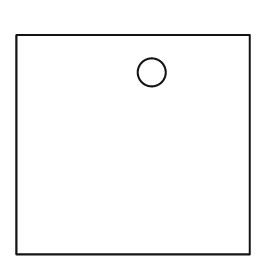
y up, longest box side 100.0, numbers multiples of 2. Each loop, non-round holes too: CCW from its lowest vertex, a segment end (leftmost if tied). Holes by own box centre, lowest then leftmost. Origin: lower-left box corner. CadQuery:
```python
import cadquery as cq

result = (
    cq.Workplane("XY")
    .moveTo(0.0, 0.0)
    .lineTo(100.0, 0.0)
    .lineTo(100.0, 94.0)
    .lineTo(0.0, 94.0)
    .close()
    .moveTo(58.0, 78.0)
    .circle(6.0)
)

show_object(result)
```